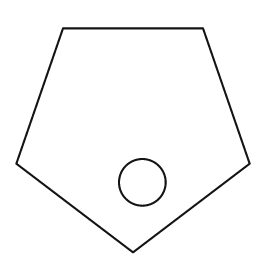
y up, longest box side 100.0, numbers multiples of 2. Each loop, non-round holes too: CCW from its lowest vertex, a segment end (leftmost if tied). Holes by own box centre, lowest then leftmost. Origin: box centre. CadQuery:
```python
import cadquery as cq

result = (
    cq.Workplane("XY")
    .moveTo(0.0, -48.0)
    .lineTo(50.0, -10.0)
    .lineTo(30.0, 48.0)
    .lineTo(-30.0, 48.0)
    .lineTo(-50.0, -10.0)
    .close()
    .moveTo(4.0, -18.0)
    .circle(10.0)
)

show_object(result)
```